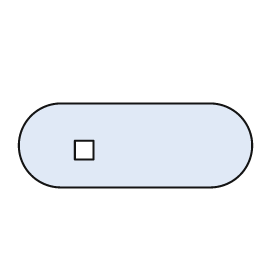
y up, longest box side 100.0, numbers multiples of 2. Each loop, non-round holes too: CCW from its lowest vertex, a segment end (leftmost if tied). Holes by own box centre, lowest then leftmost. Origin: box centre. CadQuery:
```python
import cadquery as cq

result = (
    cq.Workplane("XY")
    .moveTo(-32.0, -18.0)
    .lineTo(32.0, -18.0)
    .threePointArc((50.0, 0.0), (32.0, 18.0))
    .lineTo(-32.0, 18.0)
    .threePointArc((-50.0, 0.0), (-32.0, -18.0))
    .close()
    .moveTo(-26.0, -6.0)
    .lineTo(-18.0, -6.0)
    .lineTo(-18.0, 2.0)
    .lineTo(-26.0, 2.0)
    .close()
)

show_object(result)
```